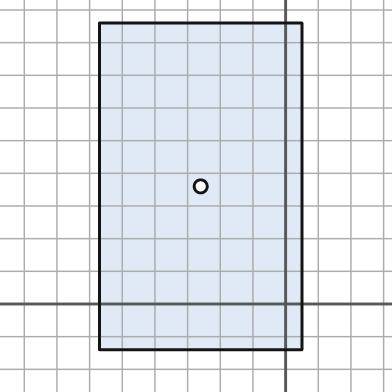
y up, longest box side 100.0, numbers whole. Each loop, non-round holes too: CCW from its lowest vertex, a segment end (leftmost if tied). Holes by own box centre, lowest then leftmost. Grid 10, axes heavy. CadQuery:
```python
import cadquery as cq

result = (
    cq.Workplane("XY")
    .moveTo(-57.0, -14.0)
    .lineTo(5.0, -14.0)
    .lineTo(5.0, 86.0)
    .lineTo(-57.0, 86.0)
    .close()
    .moveTo(-26.0, 36.0)
    .circle(2.0)
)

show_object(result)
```